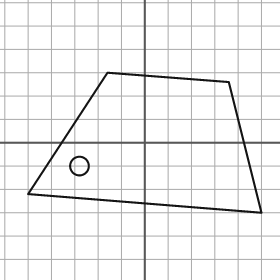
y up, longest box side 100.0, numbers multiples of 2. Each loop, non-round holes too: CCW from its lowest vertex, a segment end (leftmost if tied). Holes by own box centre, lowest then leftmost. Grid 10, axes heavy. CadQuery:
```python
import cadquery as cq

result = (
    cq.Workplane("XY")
    .moveTo(50.0, -30.0)
    .lineTo(36.0, 26.0)
    .lineTo(-16.0, 30.0)
    .lineTo(-50.0, -22.0)
    .close()
    .moveTo(-28.0, -10.0)
    .circle(4.0)
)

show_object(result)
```